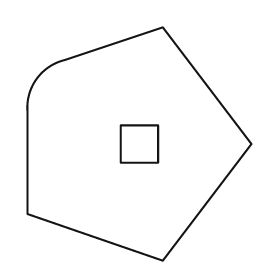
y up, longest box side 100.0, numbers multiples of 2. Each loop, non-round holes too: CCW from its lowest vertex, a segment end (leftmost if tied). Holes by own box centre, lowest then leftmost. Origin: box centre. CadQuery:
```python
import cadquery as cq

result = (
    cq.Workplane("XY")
    .moveTo(10.0, -50.0)
    .lineTo(48.0, 0.0)
    .lineTo(10.0, 50.0)
    .lineTo(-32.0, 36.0)
    .threePointArc((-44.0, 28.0), (-48.0, 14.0))
    .lineTo(-48.0, -30.0)
    .close()
    .moveTo(-8.0, -8.0)
    .lineTo(8.0, -8.0)
    .lineTo(8.0, 8.0)
    .lineTo(-8.0, 8.0)
    .close()
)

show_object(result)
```